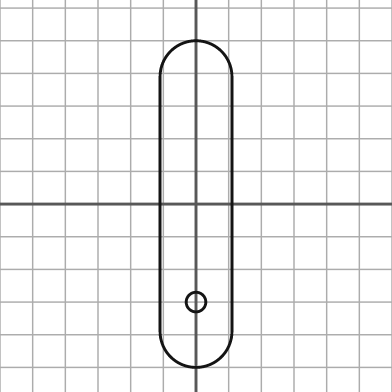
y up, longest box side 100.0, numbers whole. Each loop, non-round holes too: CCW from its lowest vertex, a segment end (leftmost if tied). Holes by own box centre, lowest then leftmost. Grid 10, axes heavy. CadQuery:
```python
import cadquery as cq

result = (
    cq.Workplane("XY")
    .moveTo(-11.0, -39.0)
    .threePointArc((0.0, -50.0), (11.0, -39.0))
    .lineTo(11.0, 39.0)
    .threePointArc((0.0, 50.0), (-11.0, 39.0))
    .close()
    .moveTo(0.0, -30.0)
    .circle(3.0)
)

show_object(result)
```